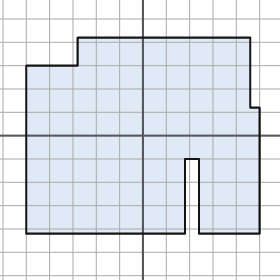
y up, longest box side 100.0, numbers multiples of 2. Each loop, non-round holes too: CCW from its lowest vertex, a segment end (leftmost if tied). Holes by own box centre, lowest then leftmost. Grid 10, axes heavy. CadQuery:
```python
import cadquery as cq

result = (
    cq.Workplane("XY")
    .moveTo(-50.0, -42.0)
    .lineTo(18.0, -42.0)
    .lineTo(18.0, -10.0)
    .lineTo(24.0, -10.0)
    .lineTo(24.0, -42.0)
    .lineTo(50.0, -42.0)
    .lineTo(50.0, 12.0)
    .lineTo(46.0, 12.0)
    .lineTo(46.0, 42.0)
    .lineTo(-28.0, 42.0)
    .lineTo(-28.0, 30.0)
    .lineTo(-50.0, 30.0)
    .close()
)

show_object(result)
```